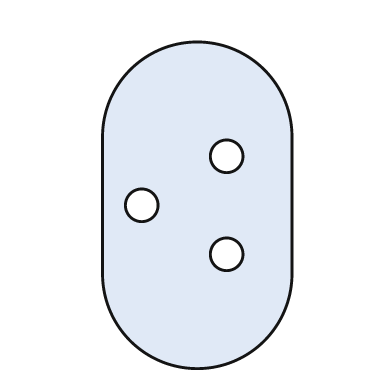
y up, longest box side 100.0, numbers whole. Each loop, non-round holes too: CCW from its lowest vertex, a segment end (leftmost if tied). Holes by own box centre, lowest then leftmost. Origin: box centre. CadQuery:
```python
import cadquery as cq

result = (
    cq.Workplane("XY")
    .moveTo(-29.0, -21.0)
    .threePointArc((0.0, -50.0), (29.0, -21.0))
    .lineTo(29.0, 21.0)
    .threePointArc((0.0, 50.0), (-29.0, 21.0))
    .close()
    .moveTo(9.0, -15.0)
    .circle(5.0)
    .moveTo(-17.0, 0.0)
    .circle(5.0)
    .moveTo(9.0, 15.0)
    .circle(5.0)
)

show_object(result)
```